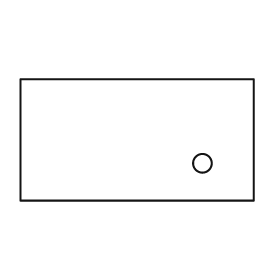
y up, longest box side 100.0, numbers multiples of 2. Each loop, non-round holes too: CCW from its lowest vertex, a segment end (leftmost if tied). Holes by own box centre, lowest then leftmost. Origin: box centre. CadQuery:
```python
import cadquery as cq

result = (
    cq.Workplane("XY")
    .moveTo(-50.0, -26.0)
    .lineTo(50.0, -26.0)
    .lineTo(50.0, 26.0)
    .lineTo(-50.0, 26.0)
    .close()
    .moveTo(28.0, -10.0)
    .circle(4.0)
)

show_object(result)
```